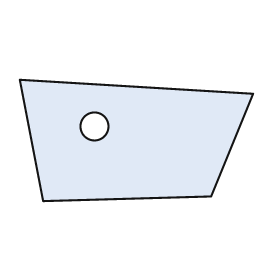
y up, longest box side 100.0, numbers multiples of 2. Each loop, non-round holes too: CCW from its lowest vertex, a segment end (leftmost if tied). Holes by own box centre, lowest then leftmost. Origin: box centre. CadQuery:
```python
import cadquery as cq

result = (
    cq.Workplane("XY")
    .moveTo(-40.0, -26.0)
    .lineTo(32.0, -24.0)
    .lineTo(50.0, 20.0)
    .lineTo(-50.0, 26.0)
    .close()
    .moveTo(-18.0, 6.0)
    .circle(6.0)
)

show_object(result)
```